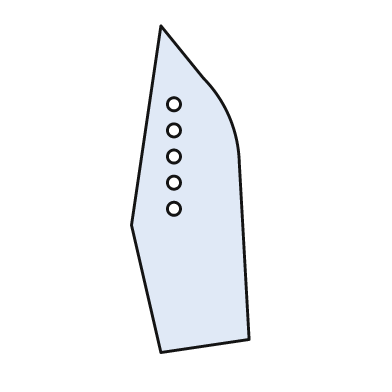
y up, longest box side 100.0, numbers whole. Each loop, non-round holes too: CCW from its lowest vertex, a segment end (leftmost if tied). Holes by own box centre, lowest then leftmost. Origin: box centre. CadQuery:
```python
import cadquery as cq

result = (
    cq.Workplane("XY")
    .moveTo(-9.0, -50.0)
    .lineTo(18.0, -46.0)
    .lineTo(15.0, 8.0)
    .threePointArc((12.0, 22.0), (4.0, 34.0))
    .lineTo(-9.0, 50.0)
    .lineTo(-18.0, -11.0)
    .close()
    .moveTo(-5.0, -6.0)
    .circle(2.0)
    .moveTo(-5.0, 2.0)
    .circle(2.0)
    .moveTo(-5.0, 10.0)
    .circle(2.0)
    .moveTo(-5.0, 18.0)
    .circle(2.0)
    .moveTo(-5.0, 26.0)
    .circle(2.0)
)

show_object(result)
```